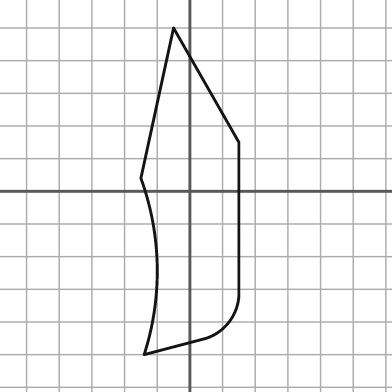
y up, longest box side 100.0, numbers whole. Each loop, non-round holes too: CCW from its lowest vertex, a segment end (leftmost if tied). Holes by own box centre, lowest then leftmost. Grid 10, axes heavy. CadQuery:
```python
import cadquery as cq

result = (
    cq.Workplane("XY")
    .moveTo(-14.0, -50.0)
    .lineTo(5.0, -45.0)
    .threePointArc((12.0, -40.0), (15.0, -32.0))
    .lineTo(15.0, 15.0)
    .lineTo(-5.0, 50.0)
    .lineTo(-15.0, 4.0)
    .threePointArc((-10.0, -23.0), (-14.0, -50.0))
    .close()
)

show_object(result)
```